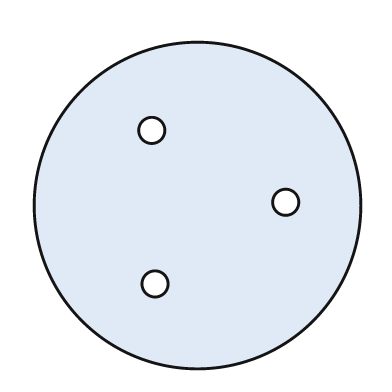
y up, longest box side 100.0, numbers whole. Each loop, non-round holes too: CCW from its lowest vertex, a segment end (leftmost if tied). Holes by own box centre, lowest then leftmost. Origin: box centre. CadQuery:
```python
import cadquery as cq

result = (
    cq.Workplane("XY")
    .moveTo(0.0, 0.0)
    .circle(50.0)
    .moveTo(-13.0, -24.0)
    .circle(4.0)
    .moveTo(27.0, 1.0)
    .circle(4.0)
    .moveTo(-14.0, 23.0)
    .circle(4.0)
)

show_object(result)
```